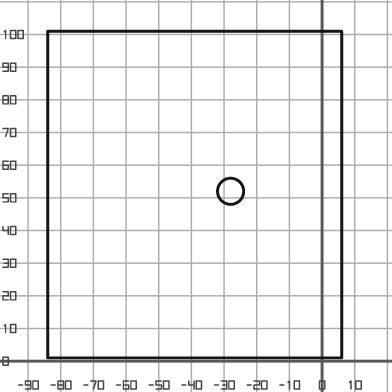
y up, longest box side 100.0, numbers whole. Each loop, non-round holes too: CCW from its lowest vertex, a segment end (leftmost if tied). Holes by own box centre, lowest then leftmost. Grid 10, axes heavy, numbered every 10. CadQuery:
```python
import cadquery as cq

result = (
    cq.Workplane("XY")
    .moveTo(-84.0, 1.0)
    .lineTo(6.0, 1.0)
    .lineTo(6.0, 101.0)
    .lineTo(-84.0, 101.0)
    .close()
    .moveTo(-28.0, 52.0)
    .circle(4.0)
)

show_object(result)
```